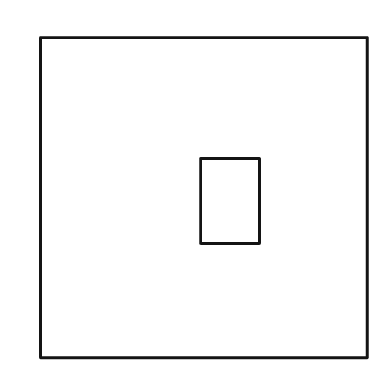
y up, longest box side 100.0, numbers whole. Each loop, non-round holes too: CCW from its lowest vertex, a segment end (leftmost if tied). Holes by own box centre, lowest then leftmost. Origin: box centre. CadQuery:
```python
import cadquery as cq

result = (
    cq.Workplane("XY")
    .moveTo(-50.0, -49.0)
    .lineTo(50.0, -49.0)
    .lineTo(50.0, 49.0)
    .lineTo(-50.0, 49.0)
    .close()
    .moveTo(-1.0, -14.0)
    .lineTo(17.0, -14.0)
    .lineTo(17.0, 12.0)
    .lineTo(-1.0, 12.0)
    .close()
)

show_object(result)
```